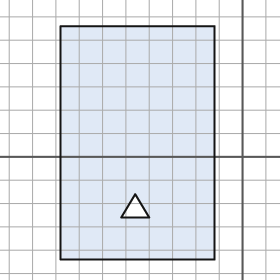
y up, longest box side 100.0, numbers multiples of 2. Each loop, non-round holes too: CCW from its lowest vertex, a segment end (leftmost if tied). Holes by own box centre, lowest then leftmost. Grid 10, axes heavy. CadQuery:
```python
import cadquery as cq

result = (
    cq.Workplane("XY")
    .moveTo(-78.0, -44.0)
    .lineTo(-12.0, -44.0)
    .lineTo(-12.0, 56.0)
    .lineTo(-78.0, 56.0)
    .close()
    .moveTo(-52.0, -26.0)
    .lineTo(-40.0, -26.0)
    .lineTo(-46.0, -16.0)
    .close()
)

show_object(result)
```